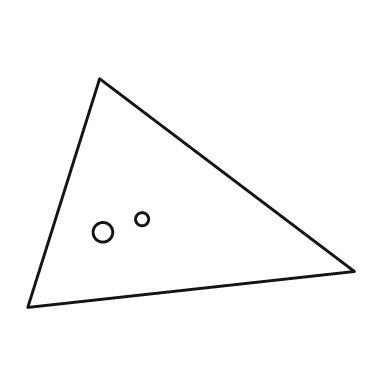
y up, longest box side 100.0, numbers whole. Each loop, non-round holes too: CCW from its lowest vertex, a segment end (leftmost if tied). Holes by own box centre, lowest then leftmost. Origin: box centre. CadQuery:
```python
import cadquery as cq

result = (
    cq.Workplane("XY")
    .moveTo(-50.0, -35.0)
    .lineTo(50.0, -24.0)
    .lineTo(-28.0, 35.0)
    .close()
    .moveTo(-27.0, -12.0)
    .circle(3.0)
    .moveTo(-15.0, -8.0)
    .circle(2.0)
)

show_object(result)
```